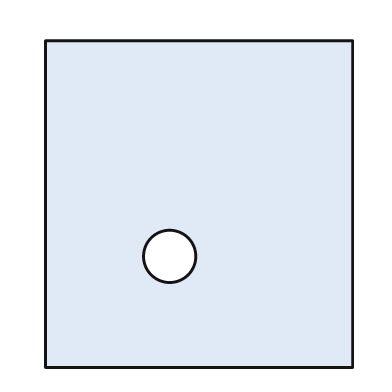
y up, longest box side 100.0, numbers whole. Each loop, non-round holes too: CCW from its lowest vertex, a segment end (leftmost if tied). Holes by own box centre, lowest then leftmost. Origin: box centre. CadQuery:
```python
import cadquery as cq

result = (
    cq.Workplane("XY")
    .moveTo(-47.0, -50.0)
    .lineTo(47.0, -50.0)
    .lineTo(47.0, 50.0)
    .lineTo(-47.0, 50.0)
    .close()
    .moveTo(-9.0, -16.0)
    .circle(8.0)
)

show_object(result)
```